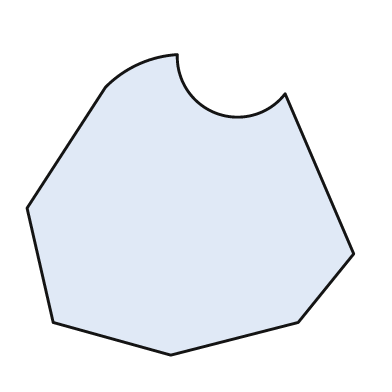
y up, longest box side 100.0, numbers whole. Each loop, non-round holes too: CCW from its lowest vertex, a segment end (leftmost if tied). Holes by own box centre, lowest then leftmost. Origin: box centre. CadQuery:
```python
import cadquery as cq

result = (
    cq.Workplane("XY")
    .moveTo(-6.0, -46.0)
    .lineTo(33.0, -36.0)
    .lineTo(50.0, -15.0)
    .lineTo(29.0, 34.0)
    .threePointArc((8.0, 28.0), (-4.0, 46.0))
    .threePointArc((-16.0, 43.0), (-26.0, 36.0))
    .lineTo(-50.0, -1.0)
    .lineTo(-42.0, -36.0)
    .close()
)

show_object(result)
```